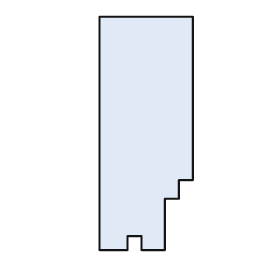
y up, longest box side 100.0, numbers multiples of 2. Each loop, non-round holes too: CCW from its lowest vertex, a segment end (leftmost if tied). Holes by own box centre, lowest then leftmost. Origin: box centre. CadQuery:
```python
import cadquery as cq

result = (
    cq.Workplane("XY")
    .moveTo(-20.0, -50.0)
    .lineTo(-8.0, -50.0)
    .lineTo(-8.0, -44.0)
    .lineTo(-2.0, -44.0)
    .lineTo(-2.0, -50.0)
    .lineTo(8.0, -50.0)
    .lineTo(8.0, -28.0)
    .lineTo(14.0, -28.0)
    .lineTo(14.0, -20.0)
    .lineTo(20.0, -20.0)
    .lineTo(20.0, 50.0)
    .lineTo(-20.0, 50.0)
    .close()
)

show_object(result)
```